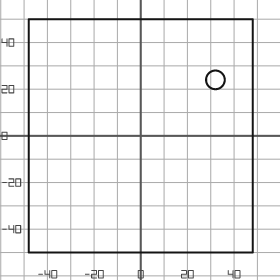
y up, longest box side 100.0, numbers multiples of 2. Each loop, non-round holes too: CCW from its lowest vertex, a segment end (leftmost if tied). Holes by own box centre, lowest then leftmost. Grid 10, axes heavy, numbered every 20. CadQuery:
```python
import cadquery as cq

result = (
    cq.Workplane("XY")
    .moveTo(-48.0, -50.0)
    .lineTo(48.0, -50.0)
    .lineTo(48.0, 50.0)
    .lineTo(-48.0, 50.0)
    .close()
    .moveTo(32.0, 24.0)
    .circle(4.0)
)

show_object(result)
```